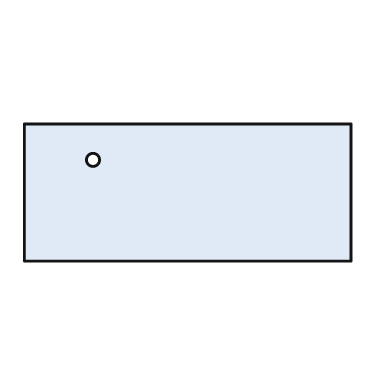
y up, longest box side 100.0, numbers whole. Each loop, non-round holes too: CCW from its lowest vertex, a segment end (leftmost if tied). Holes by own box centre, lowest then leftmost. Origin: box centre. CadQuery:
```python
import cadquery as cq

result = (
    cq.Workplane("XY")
    .moveTo(-50.0, -21.0)
    .lineTo(50.0, -21.0)
    .lineTo(50.0, 21.0)
    .lineTo(-50.0, 21.0)
    .close()
    .moveTo(-29.0, 10.0)
    .circle(2.0)
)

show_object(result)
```